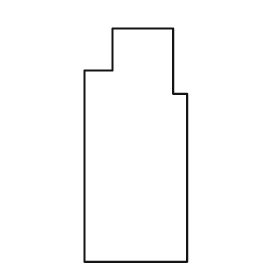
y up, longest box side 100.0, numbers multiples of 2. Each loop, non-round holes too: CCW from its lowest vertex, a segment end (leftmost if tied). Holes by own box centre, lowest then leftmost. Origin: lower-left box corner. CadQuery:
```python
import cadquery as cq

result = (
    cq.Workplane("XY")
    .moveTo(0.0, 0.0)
    .lineTo(44.0, 0.0)
    .lineTo(44.0, 72.0)
    .lineTo(38.0, 72.0)
    .lineTo(38.0, 100.0)
    .lineTo(12.0, 100.0)
    .lineTo(12.0, 82.0)
    .lineTo(0.0, 82.0)
    .close()
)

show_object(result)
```